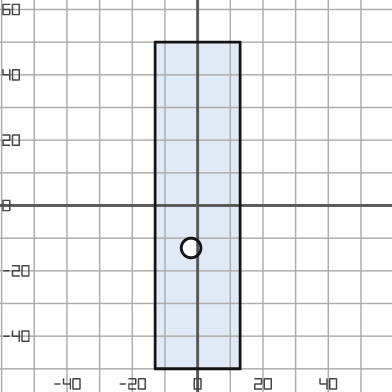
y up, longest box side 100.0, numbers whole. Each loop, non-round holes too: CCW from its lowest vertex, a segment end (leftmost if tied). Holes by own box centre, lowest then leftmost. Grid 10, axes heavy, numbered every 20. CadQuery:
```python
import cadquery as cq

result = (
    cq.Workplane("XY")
    .moveTo(-13.0, -50.0)
    .lineTo(13.0, -50.0)
    .lineTo(13.0, 50.0)
    .lineTo(-13.0, 50.0)
    .close()
    .moveTo(-2.0, -13.0)
    .circle(3.0)
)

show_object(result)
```